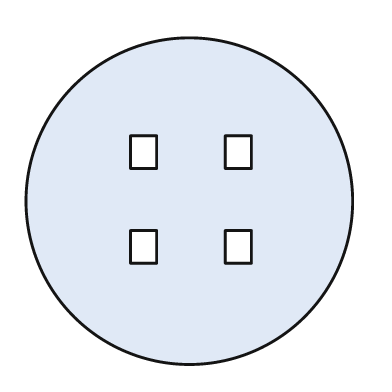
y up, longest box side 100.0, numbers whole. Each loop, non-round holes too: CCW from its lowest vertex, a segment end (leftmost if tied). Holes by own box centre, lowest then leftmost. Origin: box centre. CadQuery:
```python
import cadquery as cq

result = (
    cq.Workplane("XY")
    .moveTo(0.0, 0.0)
    .circle(50.0)
    .moveTo(-18.0, -19.0)
    .lineTo(-10.0, -19.0)
    .lineTo(-10.0, -9.0)
    .lineTo(-18.0, -9.0)
    .close()
    .moveTo(11.0, -19.0)
    .lineTo(19.0, -19.0)
    .lineTo(19.0, -9.0)
    .lineTo(11.0, -9.0)
    .close()
    .moveTo(-18.0, 10.0)
    .lineTo(-10.0, 10.0)
    .lineTo(-10.0, 20.0)
    .lineTo(-18.0, 20.0)
    .close()
    .moveTo(11.0, 10.0)
    .lineTo(19.0, 10.0)
    .lineTo(19.0, 20.0)
    .lineTo(11.0, 20.0)
    .close()
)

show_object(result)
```